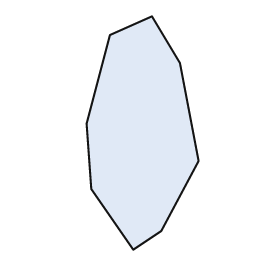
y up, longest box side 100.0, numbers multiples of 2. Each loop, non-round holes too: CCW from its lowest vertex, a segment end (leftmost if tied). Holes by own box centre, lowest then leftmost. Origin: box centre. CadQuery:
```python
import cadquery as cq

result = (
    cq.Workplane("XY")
    .moveTo(-4.0, -50.0)
    .lineTo(8.0, -42.0)
    .lineTo(24.0, -12.0)
    .lineTo(16.0, 30.0)
    .lineTo(4.0, 50.0)
    .lineTo(-14.0, 42.0)
    .lineTo(-24.0, 4.0)
    .lineTo(-22.0, -24.0)
    .close()
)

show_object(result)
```